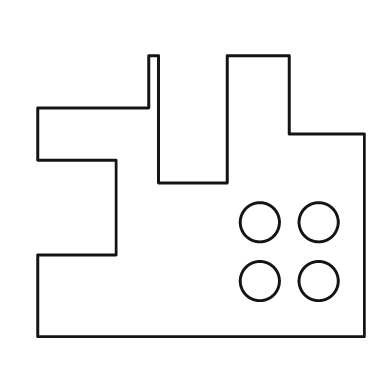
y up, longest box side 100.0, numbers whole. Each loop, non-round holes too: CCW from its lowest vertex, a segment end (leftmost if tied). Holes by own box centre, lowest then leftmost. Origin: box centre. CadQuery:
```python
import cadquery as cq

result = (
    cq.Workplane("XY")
    .moveTo(-50.0, -43.0)
    .lineTo(50.0, -43.0)
    .lineTo(50.0, 19.0)
    .lineTo(27.0, 19.0)
    .lineTo(27.0, 43.0)
    .lineTo(8.0, 43.0)
    .lineTo(8.0, 4.0)
    .lineTo(-13.0, 4.0)
    .lineTo(-13.0, 43.0)
    .lineTo(-16.0, 43.0)
    .lineTo(-16.0, 27.0)
    .lineTo(-50.0, 27.0)
    .lineTo(-50.0, 11.0)
    .lineTo(-26.0, 11.0)
    .lineTo(-26.0, -18.0)
    .lineTo(-50.0, -18.0)
    .close()
    .moveTo(18.0, -26.0)
    .circle(6.0)
    .moveTo(36.0, -26.0)
    .circle(6.0)
    .moveTo(18.0, -8.0)
    .circle(6.0)
    .moveTo(36.0, -8.0)
    .circle(6.0)
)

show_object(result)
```